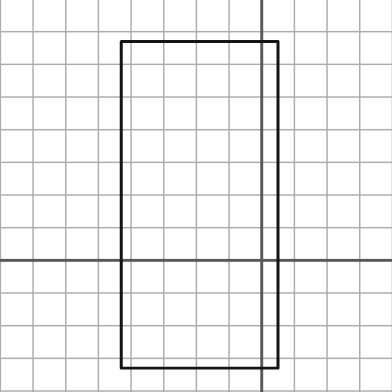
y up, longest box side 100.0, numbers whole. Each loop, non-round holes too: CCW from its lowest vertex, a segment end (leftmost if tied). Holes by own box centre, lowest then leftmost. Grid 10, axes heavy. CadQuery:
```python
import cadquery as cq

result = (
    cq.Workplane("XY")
    .moveTo(-43.0, -33.0)
    .lineTo(5.0, -33.0)
    .lineTo(5.0, 67.0)
    .lineTo(-43.0, 67.0)
    .close()
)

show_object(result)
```